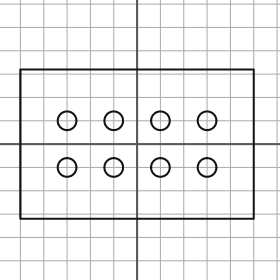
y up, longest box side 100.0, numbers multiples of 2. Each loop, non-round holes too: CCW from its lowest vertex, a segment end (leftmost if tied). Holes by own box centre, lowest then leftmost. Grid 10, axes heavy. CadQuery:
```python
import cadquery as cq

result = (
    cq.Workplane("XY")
    .moveTo(-50.0, -32.0)
    .lineTo(50.0, -32.0)
    .lineTo(50.0, 32.0)
    .lineTo(-50.0, 32.0)
    .close()
    .moveTo(-30.0, -10.0)
    .circle(4.0)
    .moveTo(-10.0, -10.0)
    .circle(4.0)
    .moveTo(10.0, -10.0)
    .circle(4.0)
    .moveTo(30.0, -10.0)
    .circle(4.0)
    .moveTo(-30.0, 10.0)
    .circle(4.0)
    .moveTo(-10.0, 10.0)
    .circle(4.0)
    .moveTo(10.0, 10.0)
    .circle(4.0)
    .moveTo(30.0, 10.0)
    .circle(4.0)
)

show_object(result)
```